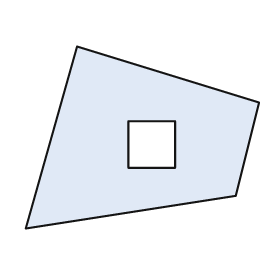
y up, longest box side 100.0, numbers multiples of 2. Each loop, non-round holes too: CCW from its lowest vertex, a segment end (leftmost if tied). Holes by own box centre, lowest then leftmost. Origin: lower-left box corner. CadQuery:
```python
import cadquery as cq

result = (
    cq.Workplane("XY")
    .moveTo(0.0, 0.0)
    .lineTo(90.0, 14.0)
    .lineTo(100.0, 54.0)
    .lineTo(22.0, 78.0)
    .close()
    .moveTo(44.0, 26.0)
    .lineTo(64.0, 26.0)
    .lineTo(64.0, 46.0)
    .lineTo(44.0, 46.0)
    .close()
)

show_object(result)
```